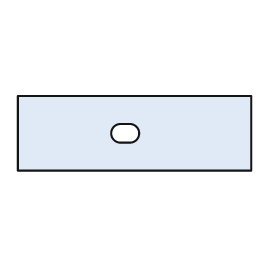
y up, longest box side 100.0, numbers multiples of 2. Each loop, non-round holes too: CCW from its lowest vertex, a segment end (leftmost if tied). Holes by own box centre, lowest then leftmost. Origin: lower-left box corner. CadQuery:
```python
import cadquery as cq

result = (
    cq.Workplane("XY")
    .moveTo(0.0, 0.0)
    .lineTo(100.0, 0.0)
    .lineTo(100.0, 32.0)
    .lineTo(0.0, 32.0)
    .close()
    .moveTo(44.0, 12.0)
    .lineTo(48.0, 12.0)
    .threePointArc((52.0, 16.0), (48.0, 20.0))
    .lineTo(44.0, 20.0)
    .threePointArc((40.0, 16.0), (44.0, 12.0))
    .close()
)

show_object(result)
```